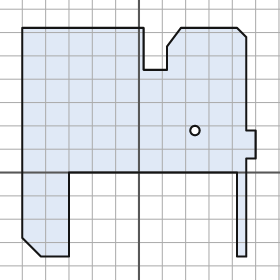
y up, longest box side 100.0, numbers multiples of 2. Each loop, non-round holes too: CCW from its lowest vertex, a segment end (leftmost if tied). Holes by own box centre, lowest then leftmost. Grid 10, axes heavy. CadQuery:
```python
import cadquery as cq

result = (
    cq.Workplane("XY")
    .moveTo(-42.0, -36.0)
    .lineTo(-30.0, -36.0)
    .lineTo(-30.0, 0.0)
    .lineTo(42.0, 0.0)
    .lineTo(42.0, -36.0)
    .lineTo(46.0, -36.0)
    .lineTo(46.0, 6.0)
    .lineTo(50.0, 6.0)
    .lineTo(50.0, 18.0)
    .lineTo(46.0, 18.0)
    .lineTo(46.0, 58.0)
    .lineTo(42.0, 62.0)
    .lineTo(18.0, 62.0)
    .lineTo(12.0, 54.0)
    .lineTo(12.0, 44.0)
    .lineTo(2.0, 44.0)
    .lineTo(2.0, 62.0)
    .lineTo(-50.0, 62.0)
    .lineTo(-50.0, -28.0)
    .close()
    .moveTo(24.0, 18.0)
    .circle(2.0)
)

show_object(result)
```